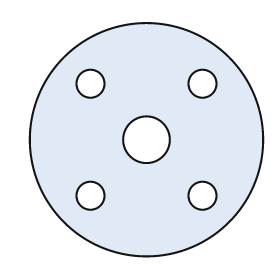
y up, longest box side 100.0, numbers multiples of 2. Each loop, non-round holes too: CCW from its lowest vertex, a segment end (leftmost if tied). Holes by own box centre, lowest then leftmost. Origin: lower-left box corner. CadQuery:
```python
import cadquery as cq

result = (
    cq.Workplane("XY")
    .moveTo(50.0, 50.0)
    .circle(50.0)
    .moveTo(26.0, 26.0)
    .circle(6.0)
    .moveTo(74.0, 26.0)
    .circle(6.0)
    .moveTo(50.0, 50.0)
    .circle(10.0)
    .moveTo(26.0, 74.0)
    .circle(6.0)
    .moveTo(74.0, 74.0)
    .circle(6.0)
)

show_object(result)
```